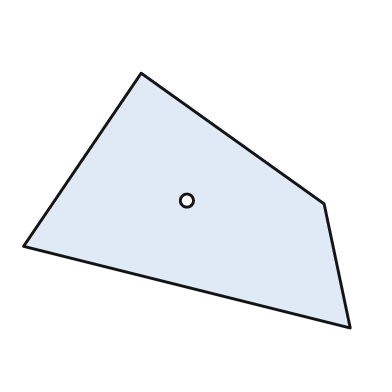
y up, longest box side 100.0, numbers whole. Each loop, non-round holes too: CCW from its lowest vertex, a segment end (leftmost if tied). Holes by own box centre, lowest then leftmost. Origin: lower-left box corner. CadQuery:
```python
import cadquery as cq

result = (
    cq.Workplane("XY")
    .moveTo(100.0, 0.0)
    .lineTo(92.0, 38.0)
    .lineTo(36.0, 78.0)
    .lineTo(0.0, 25.0)
    .close()
    .moveTo(50.0, 39.0)
    .circle(2.0)
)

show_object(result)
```